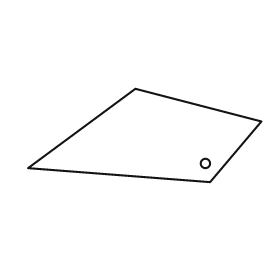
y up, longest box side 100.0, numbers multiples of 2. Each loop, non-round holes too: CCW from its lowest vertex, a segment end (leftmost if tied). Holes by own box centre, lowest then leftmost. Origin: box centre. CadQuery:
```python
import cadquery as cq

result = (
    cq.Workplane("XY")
    .moveTo(28.0, -20.0)
    .lineTo(50.0, 6.0)
    .lineTo(-4.0, 20.0)
    .lineTo(-50.0, -14.0)
    .close()
    .moveTo(26.0, -12.0)
    .circle(2.0)
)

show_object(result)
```